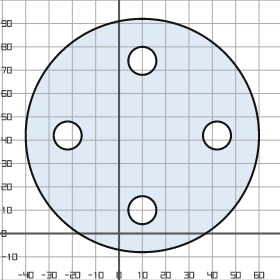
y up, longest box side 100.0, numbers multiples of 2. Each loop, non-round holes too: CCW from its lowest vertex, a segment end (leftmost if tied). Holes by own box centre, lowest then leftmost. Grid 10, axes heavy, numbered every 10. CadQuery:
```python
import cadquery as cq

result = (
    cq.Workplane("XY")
    .moveTo(10.0, 42.0)
    .circle(50.0)
    .moveTo(10.0, 10.0)
    .circle(6.0)
    .moveTo(-22.0, 42.0)
    .circle(6.0)
    .moveTo(42.0, 42.0)
    .circle(6.0)
    .moveTo(10.0, 74.0)
    .circle(6.0)
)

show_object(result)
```